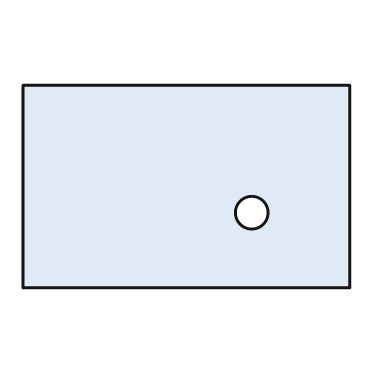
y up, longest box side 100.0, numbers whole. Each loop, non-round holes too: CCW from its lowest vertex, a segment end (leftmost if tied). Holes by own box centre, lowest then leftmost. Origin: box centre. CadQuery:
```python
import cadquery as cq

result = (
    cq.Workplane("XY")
    .moveTo(-50.0, -31.0)
    .lineTo(50.0, -31.0)
    .lineTo(50.0, 31.0)
    .lineTo(-50.0, 31.0)
    .close()
    .moveTo(20.0, -8.0)
    .circle(5.0)
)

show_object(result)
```